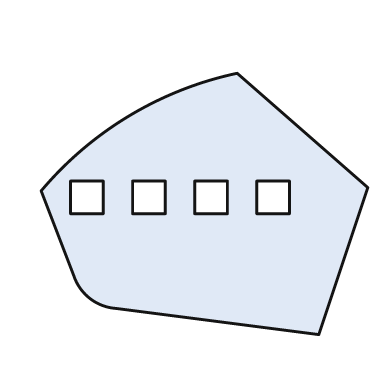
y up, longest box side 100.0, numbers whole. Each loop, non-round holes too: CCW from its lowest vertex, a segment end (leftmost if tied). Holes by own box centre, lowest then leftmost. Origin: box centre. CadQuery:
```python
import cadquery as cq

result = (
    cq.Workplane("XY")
    .moveTo(35.0, -40.0)
    .lineTo(50.0, 5.0)
    .lineTo(10.0, 40.0)
    .threePointArc((-23.0, 27.0), (-50.0, 4.0))
    .lineTo(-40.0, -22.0)
    .threePointArc((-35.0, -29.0), (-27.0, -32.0))
    .close()
    .moveTo(-41.0, -3.0)
    .lineTo(-31.0, -3.0)
    .lineTo(-31.0, 7.0)
    .lineTo(-41.0, 7.0)
    .close()
    .moveTo(-22.0, -3.0)
    .lineTo(-12.0, -3.0)
    .lineTo(-12.0, 7.0)
    .lineTo(-22.0, 7.0)
    .close()
    .moveTo(-3.0, -3.0)
    .lineTo(7.0, -3.0)
    .lineTo(7.0, 7.0)
    .lineTo(-3.0, 7.0)
    .close()
    .moveTo(16.0, -3.0)
    .lineTo(26.0, -3.0)
    .lineTo(26.0, 7.0)
    .lineTo(16.0, 7.0)
    .close()
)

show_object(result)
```